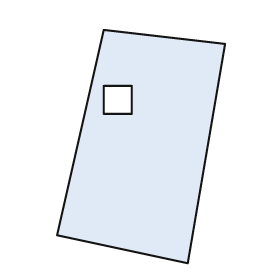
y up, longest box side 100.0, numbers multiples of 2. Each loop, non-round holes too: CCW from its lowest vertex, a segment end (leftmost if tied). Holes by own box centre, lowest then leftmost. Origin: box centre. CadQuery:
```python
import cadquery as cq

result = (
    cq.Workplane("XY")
    .moveTo(20.0, -50.0)
    .lineTo(36.0, 44.0)
    .lineTo(-16.0, 50.0)
    .lineTo(-36.0, -38.0)
    .close()
    .moveTo(-16.0, 14.0)
    .lineTo(-4.0, 14.0)
    .lineTo(-4.0, 26.0)
    .lineTo(-16.0, 26.0)
    .close()
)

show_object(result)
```